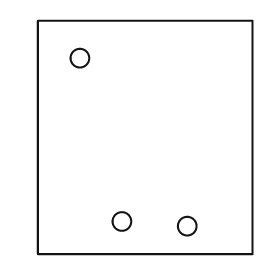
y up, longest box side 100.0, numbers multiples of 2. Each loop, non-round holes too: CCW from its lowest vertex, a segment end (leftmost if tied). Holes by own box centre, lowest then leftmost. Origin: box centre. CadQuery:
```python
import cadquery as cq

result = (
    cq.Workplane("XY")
    .moveTo(-46.0, -50.0)
    .lineTo(46.0, -50.0)
    .lineTo(46.0, 50.0)
    .lineTo(-46.0, 50.0)
    .close()
    .moveTo(18.0, -38.0)
    .circle(4.0)
    .moveTo(-10.0, -36.0)
    .circle(4.0)
    .moveTo(-28.0, 34.0)
    .circle(4.0)
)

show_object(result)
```